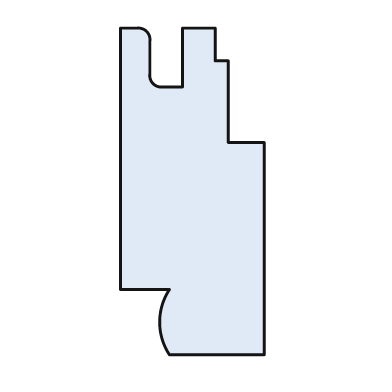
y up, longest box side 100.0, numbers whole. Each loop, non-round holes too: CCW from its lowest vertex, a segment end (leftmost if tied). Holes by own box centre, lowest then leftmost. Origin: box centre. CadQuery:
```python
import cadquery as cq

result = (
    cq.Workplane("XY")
    .moveTo(-7.0, -50.0)
    .lineTo(22.0, -50.0)
    .lineTo(22.0, 15.0)
    .lineTo(11.0, 15.0)
    .lineTo(11.0, 40.0)
    .lineTo(7.0, 40.0)
    .lineTo(7.0, 50.0)
    .lineTo(-3.0, 50.0)
    .lineTo(-3.0, 32.0)
    .lineTo(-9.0, 32.0)
    .threePointArc((-12.0, 33.0), (-13.0, 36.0))
    .lineTo(-13.0, 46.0)
    .threePointArc((-14.0, 49.0), (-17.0, 50.0))
    .lineTo(-22.0, 50.0)
    .lineTo(-22.0, -30.0)
    .lineTo(-7.0, -30.0)
    .threePointArc((-10.0, -40.0), (-7.0, -50.0))
    .close()
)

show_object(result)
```